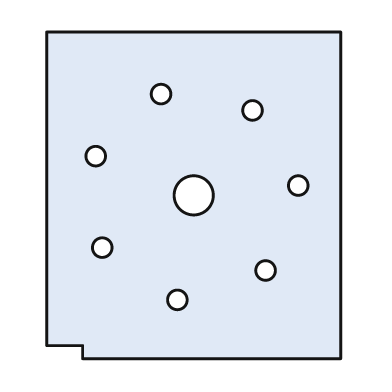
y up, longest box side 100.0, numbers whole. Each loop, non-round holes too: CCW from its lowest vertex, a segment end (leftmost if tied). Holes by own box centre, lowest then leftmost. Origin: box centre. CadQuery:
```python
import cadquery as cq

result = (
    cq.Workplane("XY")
    .moveTo(-34.0, -50.0)
    .lineTo(45.0, -50.0)
    .lineTo(45.0, 50.0)
    .lineTo(-45.0, 50.0)
    .lineTo(-45.0, -46.0)
    .lineTo(-34.0, -46.0)
    .close()
    .moveTo(-5.0, -32.0)
    .circle(3.0)
    .moveTo(22.0, -23.0)
    .circle(3.0)
    .moveTo(-28.0, -16.0)
    .circle(3.0)
    .moveTo(0.0, 0.0)
    .circle(6.0)
    .moveTo(32.0, 3.0)
    .circle(3.0)
    .moveTo(-30.0, 12.0)
    .circle(3.0)
    .moveTo(18.0, 26.0)
    .circle(3.0)
    .moveTo(-10.0, 31.0)
    .circle(3.0)
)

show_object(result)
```